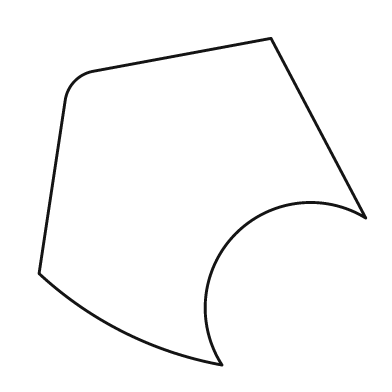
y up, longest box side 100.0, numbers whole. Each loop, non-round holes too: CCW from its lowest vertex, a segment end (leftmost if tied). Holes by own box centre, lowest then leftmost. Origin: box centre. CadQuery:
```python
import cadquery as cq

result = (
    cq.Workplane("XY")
    .moveTo(6.0, -50.0)
    .threePointArc((10.0, -10.0), (50.0, -5.0))
    .lineTo(21.0, 50.0)
    .lineTo(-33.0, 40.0)
    .threePointArc((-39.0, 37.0), (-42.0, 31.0))
    .lineTo(-50.0, -22.0)
    .threePointArc((-24.0, -40.0), (6.0, -50.0))
    .close()
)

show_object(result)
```